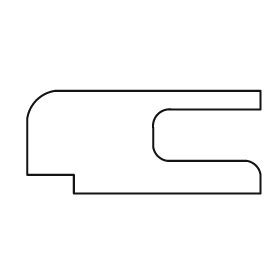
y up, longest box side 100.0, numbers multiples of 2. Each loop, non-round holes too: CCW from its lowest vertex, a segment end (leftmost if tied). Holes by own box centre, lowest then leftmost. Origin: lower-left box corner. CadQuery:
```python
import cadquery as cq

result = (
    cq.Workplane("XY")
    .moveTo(20.0, 0.0)
    .lineTo(100.0, 0.0)
    .lineTo(100.0, 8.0)
    .threePointArc((98.0, 12.0), (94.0, 14.0))
    .lineTo(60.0, 14.0)
    .threePointArc((56.0, 16.0), (54.0, 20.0))
    .lineTo(54.0, 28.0)
    .threePointArc((56.0, 34.0), (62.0, 36.0))
    .lineTo(100.0, 36.0)
    .lineTo(100.0, 44.0)
    .lineTo(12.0, 44.0)
    .threePointArc((4.0, 40.0), (0.0, 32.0))
    .lineTo(0.0, 8.0)
    .lineTo(20.0, 8.0)
    .close()
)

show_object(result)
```